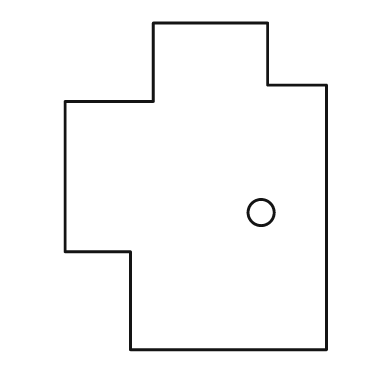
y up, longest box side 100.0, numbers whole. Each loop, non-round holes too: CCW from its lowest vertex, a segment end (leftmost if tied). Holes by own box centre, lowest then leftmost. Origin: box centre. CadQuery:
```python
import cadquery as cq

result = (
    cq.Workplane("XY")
    .moveTo(-20.0, -50.0)
    .lineTo(40.0, -50.0)
    .lineTo(40.0, 31.0)
    .lineTo(22.0, 31.0)
    .lineTo(22.0, 50.0)
    .lineTo(-13.0, 50.0)
    .lineTo(-13.0, 26.0)
    .lineTo(-40.0, 26.0)
    .lineTo(-40.0, -20.0)
    .lineTo(-20.0, -20.0)
    .close()
    .moveTo(20.0, -8.0)
    .circle(4.0)
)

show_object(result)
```